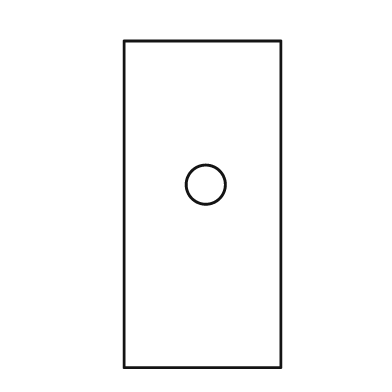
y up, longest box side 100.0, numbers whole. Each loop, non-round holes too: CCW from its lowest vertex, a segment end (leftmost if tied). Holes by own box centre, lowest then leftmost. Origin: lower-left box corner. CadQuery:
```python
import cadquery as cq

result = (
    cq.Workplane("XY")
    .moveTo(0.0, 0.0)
    .lineTo(48.0, 0.0)
    .lineTo(48.0, 100.0)
    .lineTo(0.0, 100.0)
    .close()
    .moveTo(25.0, 56.0)
    .circle(6.0)
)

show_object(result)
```